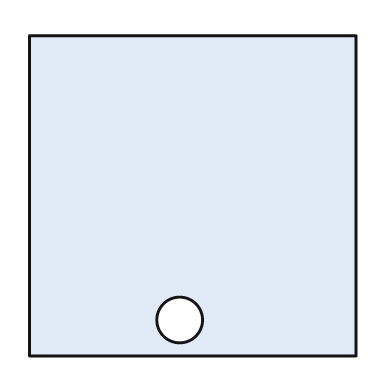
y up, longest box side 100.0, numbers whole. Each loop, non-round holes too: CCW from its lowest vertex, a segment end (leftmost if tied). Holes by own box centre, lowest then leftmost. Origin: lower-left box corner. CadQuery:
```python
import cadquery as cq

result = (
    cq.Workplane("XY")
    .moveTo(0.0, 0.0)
    .lineTo(100.0, 0.0)
    .lineTo(100.0, 98.0)
    .lineTo(0.0, 98.0)
    .close()
    .moveTo(46.0, 11.0)
    .circle(7.0)
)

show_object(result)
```